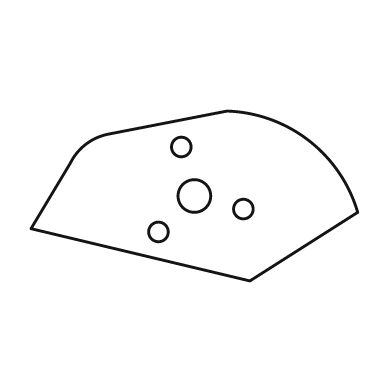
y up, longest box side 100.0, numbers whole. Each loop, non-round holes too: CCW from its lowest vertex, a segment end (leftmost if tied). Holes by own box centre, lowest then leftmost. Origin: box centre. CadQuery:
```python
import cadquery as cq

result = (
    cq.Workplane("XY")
    .moveTo(17.0, -26.0)
    .lineTo(50.0, -5.0)
    .threePointArc((35.0, 17.0), (10.0, 26.0))
    .lineTo(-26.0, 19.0)
    .threePointArc((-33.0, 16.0), (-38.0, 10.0))
    .lineTo(-50.0, -10.0)
    .close()
    .moveTo(-11.0, -11.0)
    .circle(3.0)
    .moveTo(15.0, -4.0)
    .circle(3.0)
    .moveTo(0.0, 0.0)
    .circle(5.0)
    .moveTo(-4.0, 15.0)
    .circle(3.0)
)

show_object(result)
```